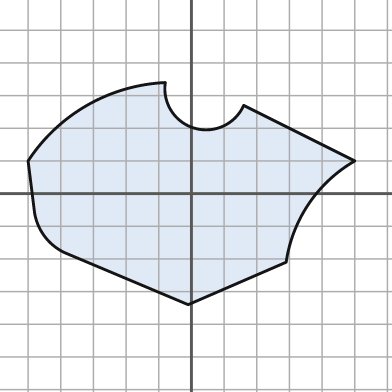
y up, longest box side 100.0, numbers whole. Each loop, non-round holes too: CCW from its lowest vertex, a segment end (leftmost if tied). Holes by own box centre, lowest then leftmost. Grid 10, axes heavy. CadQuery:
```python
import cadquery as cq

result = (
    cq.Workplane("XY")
    .moveTo(-1.0, -34.0)
    .lineTo(29.0, -21.0)
    .threePointArc((36.0, -3.0), (50.0, 10.0))
    .lineTo(16.0, 27.0)
    .threePointArc((1.0, 20.0), (-8.0, 34.0))
    .threePointArc((-32.0, 27.0), (-50.0, 10.0))
    .lineTo(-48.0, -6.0)
    .threePointArc((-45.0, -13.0), (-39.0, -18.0))
    .close()
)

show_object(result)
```